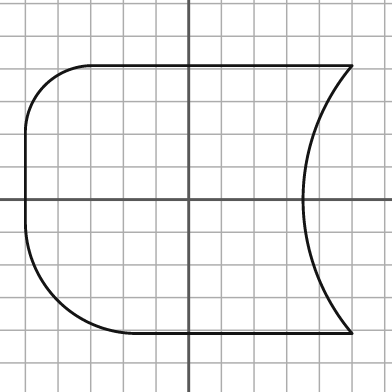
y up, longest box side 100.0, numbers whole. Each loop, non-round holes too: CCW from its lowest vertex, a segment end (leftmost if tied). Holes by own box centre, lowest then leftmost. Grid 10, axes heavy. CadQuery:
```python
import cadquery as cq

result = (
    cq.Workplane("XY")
    .moveTo(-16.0, -41.0)
    .lineTo(50.0, -41.0)
    .threePointArc((35.0, 0.0), (50.0, 41.0))
    .lineTo(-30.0, 41.0)
    .threePointArc((-44.0, 35.0), (-50.0, 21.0))
    .lineTo(-50.0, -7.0)
    .threePointArc((-40.0, -31.0), (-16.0, -41.0))
    .close()
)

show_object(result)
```